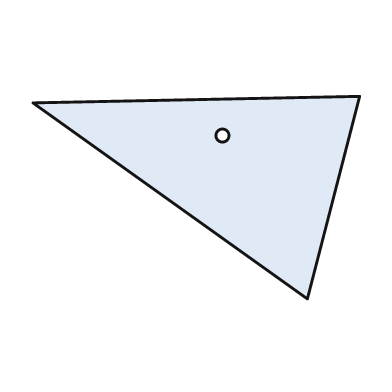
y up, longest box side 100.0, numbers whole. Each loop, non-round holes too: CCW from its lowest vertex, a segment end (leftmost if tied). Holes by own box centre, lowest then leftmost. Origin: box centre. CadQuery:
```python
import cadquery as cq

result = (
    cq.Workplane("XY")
    .moveTo(34.0, -31.0)
    .lineTo(50.0, 31.0)
    .lineTo(-50.0, 29.0)
    .close()
    .moveTo(8.0, 19.0)
    .circle(2.0)
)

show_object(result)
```